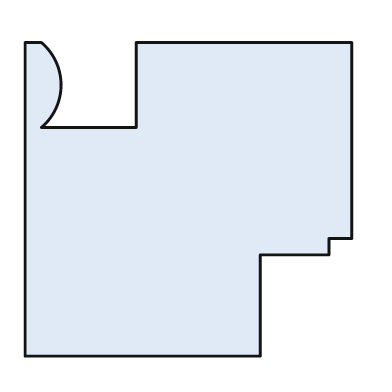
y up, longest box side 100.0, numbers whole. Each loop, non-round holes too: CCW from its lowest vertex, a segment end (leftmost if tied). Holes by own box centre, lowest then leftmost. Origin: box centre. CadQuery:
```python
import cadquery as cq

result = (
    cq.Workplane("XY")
    .moveTo(-50.0, -48.0)
    .lineTo(22.0, -48.0)
    .lineTo(22.0, -17.0)
    .lineTo(43.0, -17.0)
    .lineTo(43.0, -12.0)
    .lineTo(50.0, -12.0)
    .lineTo(50.0, 48.0)
    .lineTo(-16.0, 48.0)
    .lineTo(-16.0, 22.0)
    .lineTo(-45.0, 22.0)
    .threePointArc((-39.0, 35.0), (-45.0, 48.0))
    .lineTo(-50.0, 48.0)
    .close()
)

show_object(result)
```